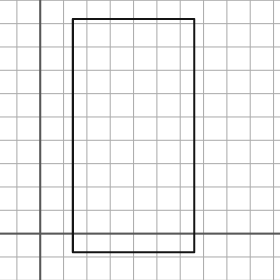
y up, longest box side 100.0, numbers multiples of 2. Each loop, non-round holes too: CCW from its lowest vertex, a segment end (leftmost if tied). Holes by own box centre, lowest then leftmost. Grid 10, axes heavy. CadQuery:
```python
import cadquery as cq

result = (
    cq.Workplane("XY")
    .moveTo(14.0, -8.0)
    .lineTo(66.0, -8.0)
    .lineTo(66.0, 92.0)
    .lineTo(14.0, 92.0)
    .close()
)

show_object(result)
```